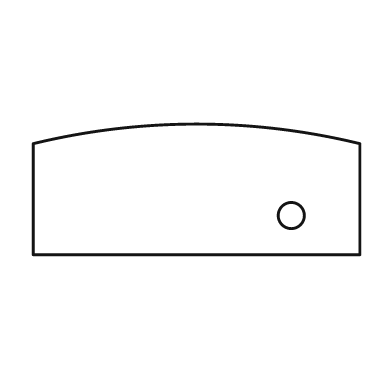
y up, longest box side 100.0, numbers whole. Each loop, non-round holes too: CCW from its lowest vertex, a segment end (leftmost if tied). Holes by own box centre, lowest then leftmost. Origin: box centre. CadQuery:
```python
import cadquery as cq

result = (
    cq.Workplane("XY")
    .moveTo(-50.0, -20.0)
    .lineTo(50.0, -20.0)
    .lineTo(50.0, 14.0)
    .threePointArc((0.0, 20.0), (-50.0, 14.0))
    .close()
    .moveTo(29.0, -8.0)
    .circle(4.0)
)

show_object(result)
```